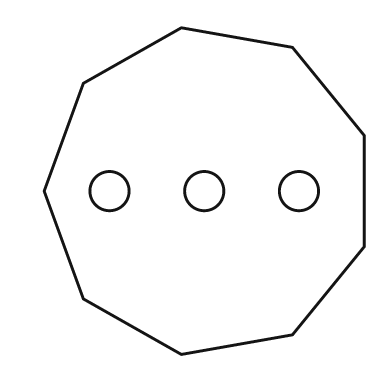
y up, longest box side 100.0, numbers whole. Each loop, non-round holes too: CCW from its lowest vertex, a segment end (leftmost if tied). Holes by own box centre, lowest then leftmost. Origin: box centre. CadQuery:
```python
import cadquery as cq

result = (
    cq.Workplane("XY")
    .moveTo(-7.0, -50.0)
    .lineTo(27.0, -44.0)
    .lineTo(49.0, -17.0)
    .lineTo(49.0, 17.0)
    .lineTo(27.0, 44.0)
    .lineTo(-7.0, 50.0)
    .lineTo(-37.0, 33.0)
    .lineTo(-49.0, 0.0)
    .lineTo(-37.0, -33.0)
    .close()
    .moveTo(-29.0, 0.0)
    .circle(6.0)
    .moveTo(0.0, 0.0)
    .circle(6.0)
    .moveTo(29.0, 0.0)
    .circle(6.0)
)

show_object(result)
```